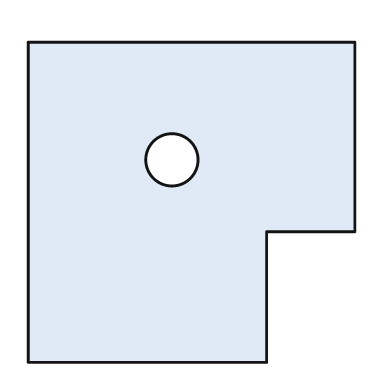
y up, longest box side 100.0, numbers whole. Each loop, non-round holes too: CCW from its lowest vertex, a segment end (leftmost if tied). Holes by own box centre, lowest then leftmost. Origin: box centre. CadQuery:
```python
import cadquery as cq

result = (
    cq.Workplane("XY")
    .moveTo(-50.0, -49.0)
    .lineTo(23.0, -49.0)
    .lineTo(23.0, -9.0)
    .lineTo(50.0, -9.0)
    .lineTo(50.0, 49.0)
    .lineTo(-50.0, 49.0)
    .close()
    .moveTo(-6.0, 13.0)
    .circle(8.0)
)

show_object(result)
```